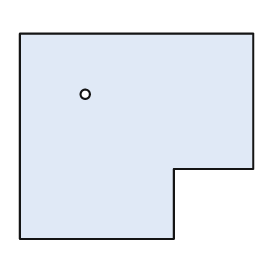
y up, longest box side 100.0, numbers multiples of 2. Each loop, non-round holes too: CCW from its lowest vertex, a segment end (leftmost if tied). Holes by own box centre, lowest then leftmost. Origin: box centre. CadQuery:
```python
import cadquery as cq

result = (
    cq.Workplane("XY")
    .moveTo(-50.0, -44.0)
    .lineTo(16.0, -44.0)
    .lineTo(16.0, -14.0)
    .lineTo(50.0, -14.0)
    .lineTo(50.0, 44.0)
    .lineTo(-50.0, 44.0)
    .close()
    .moveTo(-22.0, 18.0)
    .circle(2.0)
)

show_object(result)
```